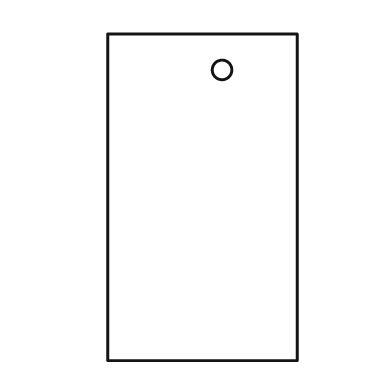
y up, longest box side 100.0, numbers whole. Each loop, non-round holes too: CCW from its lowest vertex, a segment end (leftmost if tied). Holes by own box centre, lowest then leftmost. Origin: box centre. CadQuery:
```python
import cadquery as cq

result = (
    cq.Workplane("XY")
    .moveTo(-29.0, -50.0)
    .lineTo(29.0, -50.0)
    .lineTo(29.0, 50.0)
    .lineTo(-29.0, 50.0)
    .close()
    .moveTo(6.0, 39.0)
    .circle(3.0)
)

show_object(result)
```